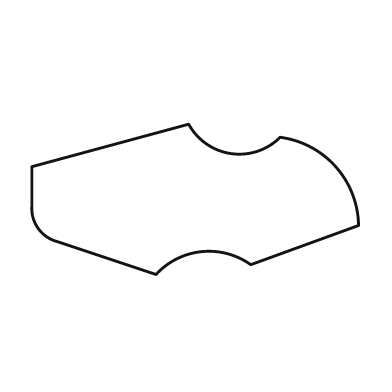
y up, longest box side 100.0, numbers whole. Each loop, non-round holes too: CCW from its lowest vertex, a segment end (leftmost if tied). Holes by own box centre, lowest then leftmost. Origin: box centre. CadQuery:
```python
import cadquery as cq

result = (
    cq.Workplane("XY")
    .moveTo(-12.0, -23.0)
    .threePointArc((2.0, -16.0), (17.0, -20.0))
    .lineTo(50.0, -8.0)
    .threePointArc((43.0, 10.0), (26.0, 19.0))
    .threePointArc((11.0, 14.0), (-2.0, 23.0))
    .lineTo(-50.0, 10.0)
    .lineTo(-50.0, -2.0)
    .threePointArc((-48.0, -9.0), (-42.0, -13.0))
    .close()
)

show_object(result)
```